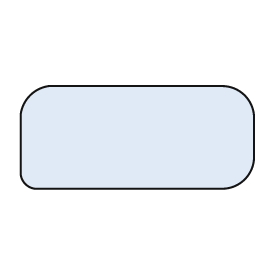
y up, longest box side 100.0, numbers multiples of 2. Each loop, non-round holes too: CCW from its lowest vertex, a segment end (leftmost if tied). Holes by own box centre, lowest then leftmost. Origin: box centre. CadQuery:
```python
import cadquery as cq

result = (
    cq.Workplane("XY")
    .moveTo(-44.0, -22.0)
    .lineTo(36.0, -22.0)
    .threePointArc((46.0, -18.0), (50.0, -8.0))
    .lineTo(50.0, 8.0)
    .threePointArc((46.0, 18.0), (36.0, 22.0))
    .lineTo(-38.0, 22.0)
    .threePointArc((-46.0, 18.0), (-50.0, 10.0))
    .lineTo(-50.0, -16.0)
    .threePointArc((-48.0, -20.0), (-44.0, -22.0))
    .close()
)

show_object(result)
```